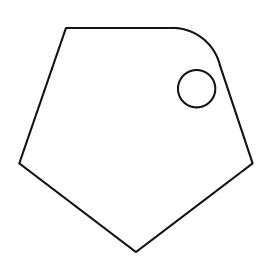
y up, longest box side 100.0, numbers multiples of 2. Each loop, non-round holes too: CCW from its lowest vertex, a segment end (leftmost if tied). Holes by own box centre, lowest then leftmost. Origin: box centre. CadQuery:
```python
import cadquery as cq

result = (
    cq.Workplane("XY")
    .moveTo(0.0, -48.0)
    .lineTo(50.0, -10.0)
    .lineTo(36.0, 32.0)
    .threePointArc((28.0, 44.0), (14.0, 48.0))
    .lineTo(-30.0, 48.0)
    .lineTo(-50.0, -10.0)
    .close()
    .moveTo(26.0, 22.0)
    .circle(8.0)
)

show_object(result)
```